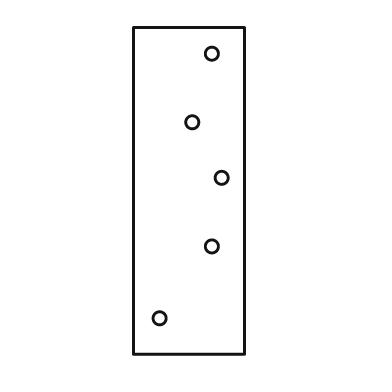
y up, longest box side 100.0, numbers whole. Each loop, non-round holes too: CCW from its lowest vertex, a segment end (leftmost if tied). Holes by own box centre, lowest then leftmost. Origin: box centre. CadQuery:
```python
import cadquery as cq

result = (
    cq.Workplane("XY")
    .moveTo(-17.0, -50.0)
    .lineTo(17.0, -50.0)
    .lineTo(17.0, 50.0)
    .lineTo(-17.0, 50.0)
    .close()
    .moveTo(-9.0, -39.0)
    .circle(2.0)
    .moveTo(7.0, -17.0)
    .circle(2.0)
    .moveTo(10.0, 4.0)
    .circle(2.0)
    .moveTo(1.0, 21.0)
    .circle(2.0)
    .moveTo(7.0, 42.0)
    .circle(2.0)
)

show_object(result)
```